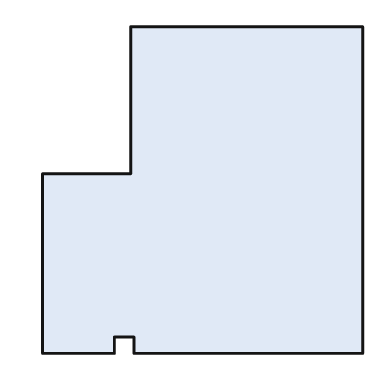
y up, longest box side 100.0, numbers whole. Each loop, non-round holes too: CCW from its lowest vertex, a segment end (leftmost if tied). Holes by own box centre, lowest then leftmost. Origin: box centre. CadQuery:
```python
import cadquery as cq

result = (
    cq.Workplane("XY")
    .moveTo(-49.0, -50.0)
    .lineTo(-27.0, -50.0)
    .lineTo(-27.0, -45.0)
    .lineTo(-21.0, -45.0)
    .lineTo(-21.0, -50.0)
    .lineTo(49.0, -50.0)
    .lineTo(49.0, 50.0)
    .lineTo(-22.0, 50.0)
    .lineTo(-22.0, 5.0)
    .lineTo(-49.0, 5.0)
    .close()
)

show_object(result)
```